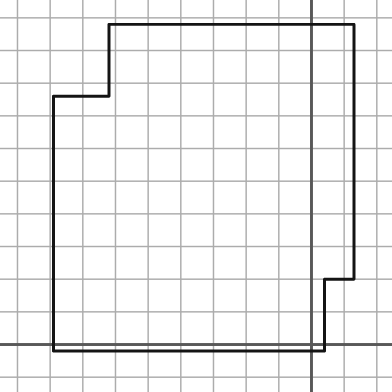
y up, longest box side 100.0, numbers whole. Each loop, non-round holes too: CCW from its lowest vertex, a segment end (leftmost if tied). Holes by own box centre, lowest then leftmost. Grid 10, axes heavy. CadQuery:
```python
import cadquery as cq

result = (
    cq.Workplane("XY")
    .moveTo(-79.0, -2.0)
    .lineTo(4.0, -2.0)
    .lineTo(4.0, 20.0)
    .lineTo(13.0, 20.0)
    .lineTo(13.0, 98.0)
    .lineTo(-62.0, 98.0)
    .lineTo(-62.0, 76.0)
    .lineTo(-79.0, 76.0)
    .close()
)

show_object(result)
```